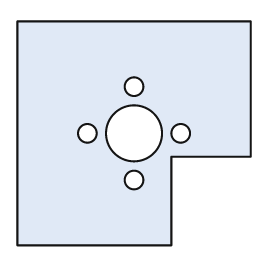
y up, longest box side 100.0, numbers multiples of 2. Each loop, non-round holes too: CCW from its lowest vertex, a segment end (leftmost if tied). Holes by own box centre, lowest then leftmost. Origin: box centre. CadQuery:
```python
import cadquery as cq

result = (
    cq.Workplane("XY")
    .moveTo(-50.0, -48.0)
    .lineTo(16.0, -48.0)
    .lineTo(16.0, -10.0)
    .lineTo(50.0, -10.0)
    .lineTo(50.0, 48.0)
    .lineTo(-50.0, 48.0)
    .close()
    .moveTo(0.0, -20.0)
    .circle(4.0)
    .moveTo(-20.0, 0.0)
    .circle(4.0)
    .moveTo(0.0, 0.0)
    .circle(12.0)
    .moveTo(20.0, 0.0)
    .circle(4.0)
    .moveTo(0.0, 20.0)
    .circle(4.0)
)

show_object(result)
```